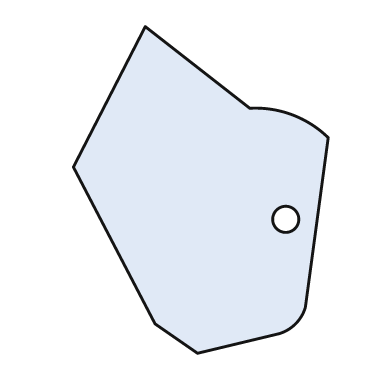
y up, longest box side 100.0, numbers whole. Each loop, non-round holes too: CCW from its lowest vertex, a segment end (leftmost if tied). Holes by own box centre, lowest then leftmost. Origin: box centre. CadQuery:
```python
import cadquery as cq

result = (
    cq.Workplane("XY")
    .moveTo(-1.0, -50.0)
    .lineTo(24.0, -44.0)
    .threePointArc((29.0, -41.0), (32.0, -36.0))
    .lineTo(39.0, 16.0)
    .threePointArc((28.0, 23.0), (15.0, 25.0))
    .lineTo(-17.0, 50.0)
    .lineTo(-39.0, 7.0)
    .lineTo(-14.0, -41.0)
    .close()
    .moveTo(26.0, -9.0)
    .circle(4.0)
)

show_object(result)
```